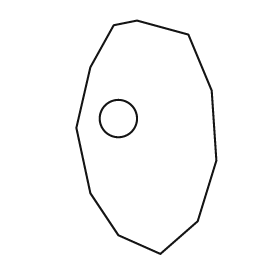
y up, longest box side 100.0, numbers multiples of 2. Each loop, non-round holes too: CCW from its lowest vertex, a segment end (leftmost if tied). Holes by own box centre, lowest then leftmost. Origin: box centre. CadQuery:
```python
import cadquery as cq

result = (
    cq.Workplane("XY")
    .moveTo(6.0, -50.0)
    .lineTo(22.0, -36.0)
    .lineTo(30.0, -10.0)
    .lineTo(28.0, 20.0)
    .lineTo(18.0, 44.0)
    .lineTo(-4.0, 50.0)
    .lineTo(-14.0, 48.0)
    .lineTo(-24.0, 30.0)
    .lineTo(-30.0, 4.0)
    .lineTo(-24.0, -24.0)
    .lineTo(-12.0, -42.0)
    .close()
    .moveTo(-12.0, 8.0)
    .circle(8.0)
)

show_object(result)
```